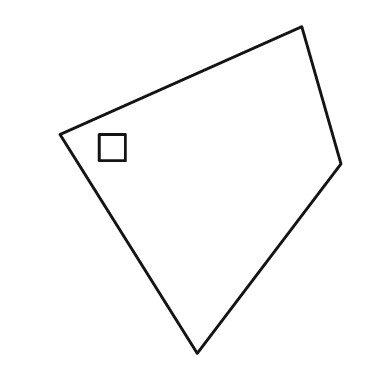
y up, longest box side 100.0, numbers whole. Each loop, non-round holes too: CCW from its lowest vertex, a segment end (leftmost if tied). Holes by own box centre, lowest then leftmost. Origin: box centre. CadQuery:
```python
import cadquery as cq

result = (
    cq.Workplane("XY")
    .moveTo(-1.0, -50.0)
    .lineTo(43.0, 8.0)
    .lineTo(31.0, 50.0)
    .lineTo(-43.0, 17.0)
    .close()
    .moveTo(-31.0, 9.0)
    .lineTo(-23.0, 9.0)
    .lineTo(-23.0, 17.0)
    .lineTo(-31.0, 17.0)
    .close()
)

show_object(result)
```